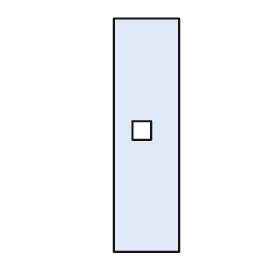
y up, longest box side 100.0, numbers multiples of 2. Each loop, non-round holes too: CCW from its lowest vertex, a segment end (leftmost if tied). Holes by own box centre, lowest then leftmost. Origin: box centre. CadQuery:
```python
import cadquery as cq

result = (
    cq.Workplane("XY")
    .moveTo(-14.0, -50.0)
    .lineTo(14.0, -50.0)
    .lineTo(14.0, 50.0)
    .lineTo(-14.0, 50.0)
    .close()
    .moveTo(-6.0, -2.0)
    .lineTo(2.0, -2.0)
    .lineTo(2.0, 6.0)
    .lineTo(-6.0, 6.0)
    .close()
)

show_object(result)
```